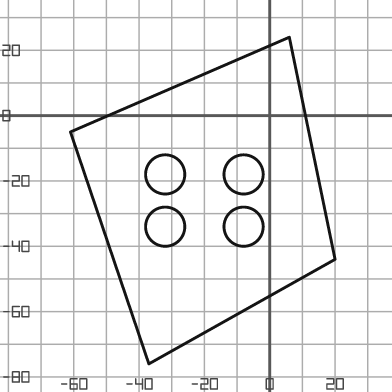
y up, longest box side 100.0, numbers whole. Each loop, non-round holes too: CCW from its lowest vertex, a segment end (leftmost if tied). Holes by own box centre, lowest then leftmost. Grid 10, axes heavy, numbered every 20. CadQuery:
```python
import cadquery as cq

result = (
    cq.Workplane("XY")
    .moveTo(-37.0, -76.0)
    .lineTo(20.0, -44.0)
    .lineTo(6.0, 24.0)
    .lineTo(-61.0, -5.0)
    .close()
    .moveTo(-32.0, -34.0)
    .circle(6.0)
    .moveTo(-8.0, -34.0)
    .circle(6.0)
    .moveTo(-32.0, -18.0)
    .circle(6.0)
    .moveTo(-8.0, -18.0)
    .circle(6.0)
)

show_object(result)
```